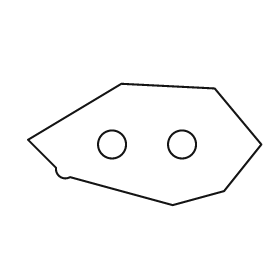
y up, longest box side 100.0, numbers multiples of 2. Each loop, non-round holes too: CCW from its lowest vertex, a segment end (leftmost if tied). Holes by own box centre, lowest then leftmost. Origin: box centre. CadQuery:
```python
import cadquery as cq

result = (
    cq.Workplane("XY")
    .moveTo(12.0, -26.0)
    .lineTo(34.0, -20.0)
    .lineTo(50.0, 0.0)
    .lineTo(30.0, 24.0)
    .lineTo(-10.0, 26.0)
    .lineTo(-50.0, 2.0)
    .lineTo(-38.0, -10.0)
    .threePointArc((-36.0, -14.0), (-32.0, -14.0))
    .close()
    .moveTo(-14.0, 0.0)
    .circle(6.0)
    .moveTo(16.0, 0.0)
    .circle(6.0)
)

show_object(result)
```